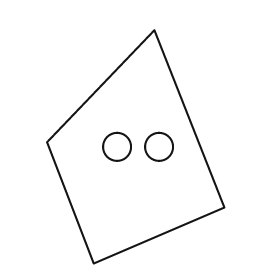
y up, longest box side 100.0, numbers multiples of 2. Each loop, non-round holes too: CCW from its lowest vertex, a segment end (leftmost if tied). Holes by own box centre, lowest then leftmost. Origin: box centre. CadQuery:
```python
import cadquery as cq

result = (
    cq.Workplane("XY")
    .moveTo(-18.0, -50.0)
    .lineTo(38.0, -26.0)
    .lineTo(8.0, 50.0)
    .lineTo(-38.0, 2.0)
    .close()
    .moveTo(-8.0, 0.0)
    .circle(6.0)
    .moveTo(10.0, 0.0)
    .circle(6.0)
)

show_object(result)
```